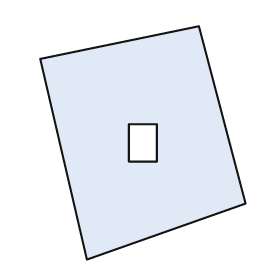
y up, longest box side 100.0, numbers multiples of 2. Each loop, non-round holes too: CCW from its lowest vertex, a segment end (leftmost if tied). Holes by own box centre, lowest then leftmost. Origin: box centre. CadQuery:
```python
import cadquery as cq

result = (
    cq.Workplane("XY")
    .moveTo(-24.0, -50.0)
    .lineTo(44.0, -26.0)
    .lineTo(24.0, 50.0)
    .lineTo(-44.0, 36.0)
    .close()
    .moveTo(-6.0, -8.0)
    .lineTo(6.0, -8.0)
    .lineTo(6.0, 8.0)
    .lineTo(-6.0, 8.0)
    .close()
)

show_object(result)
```